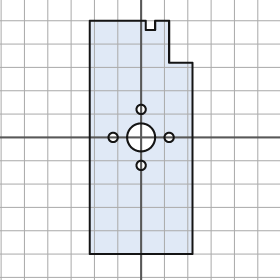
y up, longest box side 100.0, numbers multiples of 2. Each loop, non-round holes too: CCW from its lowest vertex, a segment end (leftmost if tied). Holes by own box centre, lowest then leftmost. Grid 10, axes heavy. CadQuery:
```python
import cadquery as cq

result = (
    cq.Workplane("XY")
    .moveTo(-22.0, -50.0)
    .lineTo(22.0, -50.0)
    .lineTo(22.0, 32.0)
    .lineTo(12.0, 32.0)
    .lineTo(12.0, 50.0)
    .lineTo(6.0, 50.0)
    .lineTo(6.0, 46.0)
    .lineTo(2.0, 46.0)
    .lineTo(2.0, 50.0)
    .lineTo(-22.0, 50.0)
    .close()
    .moveTo(0.0, -12.0)
    .circle(2.0)
    .moveTo(-12.0, 0.0)
    .circle(2.0)
    .moveTo(0.0, 0.0)
    .circle(6.0)
    .moveTo(12.0, 0.0)
    .circle(2.0)
    .moveTo(0.0, 12.0)
    .circle(2.0)
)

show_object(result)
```